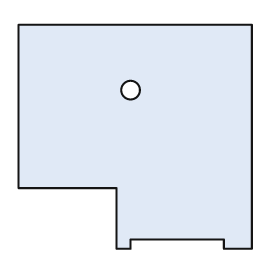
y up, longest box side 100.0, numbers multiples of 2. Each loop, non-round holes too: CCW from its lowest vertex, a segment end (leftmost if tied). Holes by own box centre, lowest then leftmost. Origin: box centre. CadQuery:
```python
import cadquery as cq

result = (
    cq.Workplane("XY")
    .moveTo(-8.0, -48.0)
    .lineTo(-2.0, -48.0)
    .lineTo(-2.0, -44.0)
    .lineTo(38.0, -44.0)
    .lineTo(38.0, -48.0)
    .lineTo(50.0, -48.0)
    .lineTo(50.0, 48.0)
    .lineTo(-50.0, 48.0)
    .lineTo(-50.0, -22.0)
    .lineTo(-8.0, -22.0)
    .close()
    .moveTo(-2.0, 20.0)
    .circle(4.0)
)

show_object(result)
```